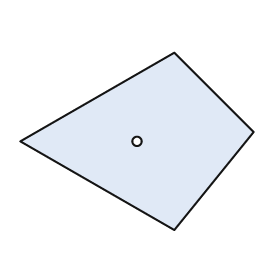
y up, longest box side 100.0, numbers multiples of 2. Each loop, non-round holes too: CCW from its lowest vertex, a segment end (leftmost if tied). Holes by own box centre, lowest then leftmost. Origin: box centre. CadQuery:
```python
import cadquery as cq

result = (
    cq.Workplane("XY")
    .moveTo(16.0, -38.0)
    .lineTo(50.0, 4.0)
    .lineTo(16.0, 38.0)
    .lineTo(-50.0, 0.0)
    .close()
    .moveTo(0.0, 0.0)
    .circle(2.0)
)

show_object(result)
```